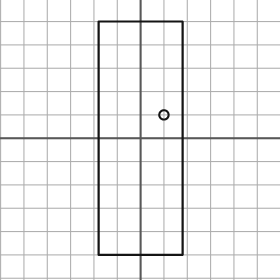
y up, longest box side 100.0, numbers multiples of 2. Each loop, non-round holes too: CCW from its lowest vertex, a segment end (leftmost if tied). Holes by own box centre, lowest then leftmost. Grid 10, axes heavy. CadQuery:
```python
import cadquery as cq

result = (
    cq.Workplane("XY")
    .moveTo(-18.0, -50.0)
    .lineTo(18.0, -50.0)
    .lineTo(18.0, 50.0)
    .lineTo(-18.0, 50.0)
    .close()
    .moveTo(10.0, 10.0)
    .circle(2.0)
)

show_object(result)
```